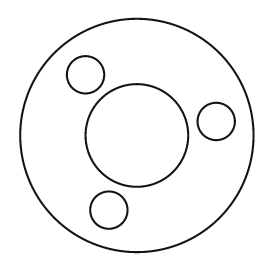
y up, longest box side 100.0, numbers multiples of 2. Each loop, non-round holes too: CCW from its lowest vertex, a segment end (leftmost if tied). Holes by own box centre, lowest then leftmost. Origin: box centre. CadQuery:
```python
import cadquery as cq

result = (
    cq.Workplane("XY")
    .moveTo(0.0, 0.0)
    .circle(50.0)
    .moveTo(-12.0, -32.0)
    .circle(8.0)
    .moveTo(0.0, 0.0)
    .circle(22.0)
    .moveTo(34.0, 6.0)
    .circle(8.0)
    .moveTo(-22.0, 26.0)
    .circle(8.0)
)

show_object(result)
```